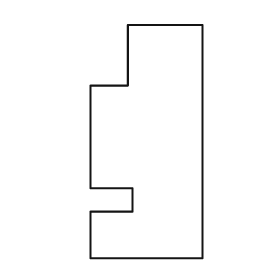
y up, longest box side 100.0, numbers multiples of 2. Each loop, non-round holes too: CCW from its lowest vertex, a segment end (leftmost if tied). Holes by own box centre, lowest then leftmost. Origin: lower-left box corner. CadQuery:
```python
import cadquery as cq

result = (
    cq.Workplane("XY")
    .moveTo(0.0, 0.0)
    .lineTo(48.0, 0.0)
    .lineTo(48.0, 100.0)
    .lineTo(16.0, 100.0)
    .lineTo(16.0, 74.0)
    .lineTo(0.0, 74.0)
    .lineTo(0.0, 30.0)
    .lineTo(18.0, 30.0)
    .lineTo(18.0, 20.0)
    .lineTo(0.0, 20.0)
    .close()
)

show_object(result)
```